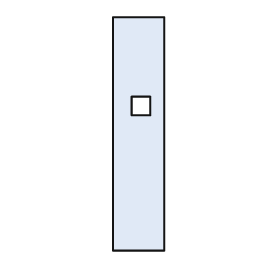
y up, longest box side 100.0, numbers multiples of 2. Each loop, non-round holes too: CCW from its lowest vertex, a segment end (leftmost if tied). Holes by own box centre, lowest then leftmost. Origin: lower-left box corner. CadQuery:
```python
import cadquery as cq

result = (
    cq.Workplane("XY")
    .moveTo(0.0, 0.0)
    .lineTo(22.0, 0.0)
    .lineTo(22.0, 100.0)
    .lineTo(0.0, 100.0)
    .close()
    .moveTo(8.0, 58.0)
    .lineTo(16.0, 58.0)
    .lineTo(16.0, 66.0)
    .lineTo(8.0, 66.0)
    .close()
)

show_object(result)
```